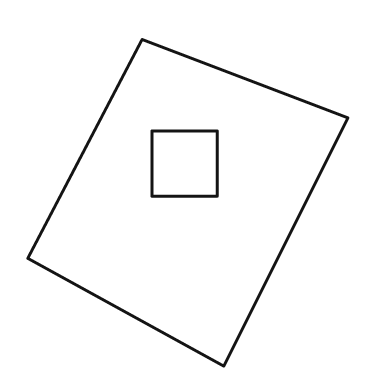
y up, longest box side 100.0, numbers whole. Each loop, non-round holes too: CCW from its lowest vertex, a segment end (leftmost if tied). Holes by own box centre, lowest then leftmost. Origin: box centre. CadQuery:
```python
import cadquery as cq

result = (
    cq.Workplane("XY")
    .moveTo(11.0, -50.0)
    .lineTo(49.0, 26.0)
    .lineTo(-14.0, 50.0)
    .lineTo(-49.0, -17.0)
    .close()
    .moveTo(-11.0, 2.0)
    .lineTo(9.0, 2.0)
    .lineTo(9.0, 22.0)
    .lineTo(-11.0, 22.0)
    .close()
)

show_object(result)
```